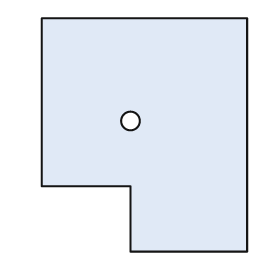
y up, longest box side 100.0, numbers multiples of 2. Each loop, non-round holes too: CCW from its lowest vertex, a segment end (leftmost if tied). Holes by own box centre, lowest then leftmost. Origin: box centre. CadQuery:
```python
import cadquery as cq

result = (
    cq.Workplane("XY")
    .moveTo(-6.0, -50.0)
    .lineTo(44.0, -50.0)
    .lineTo(44.0, 50.0)
    .lineTo(-44.0, 50.0)
    .lineTo(-44.0, -22.0)
    .lineTo(-6.0, -22.0)
    .close()
    .moveTo(-6.0, 6.0)
    .circle(4.0)
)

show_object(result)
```